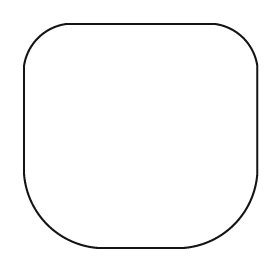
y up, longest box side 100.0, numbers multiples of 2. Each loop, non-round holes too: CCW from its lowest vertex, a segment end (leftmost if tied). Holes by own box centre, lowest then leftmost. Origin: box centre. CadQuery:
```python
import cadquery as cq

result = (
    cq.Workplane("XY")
    .moveTo(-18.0, -48.0)
    .lineTo(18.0, -48.0)
    .threePointArc((40.0, -38.0), (50.0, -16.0))
    .lineTo(50.0, 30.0)
    .threePointArc((44.0, 42.0), (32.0, 48.0))
    .lineTo(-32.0, 48.0)
    .threePointArc((-44.0, 42.0), (-50.0, 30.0))
    .lineTo(-50.0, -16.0)
    .threePointArc((-40.0, -38.0), (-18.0, -48.0))
    .close()
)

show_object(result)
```